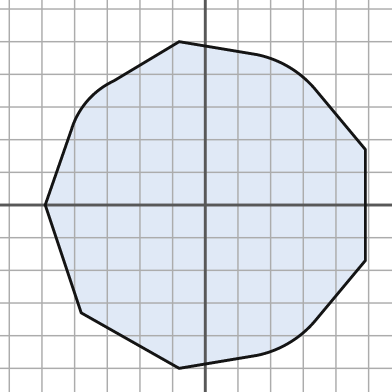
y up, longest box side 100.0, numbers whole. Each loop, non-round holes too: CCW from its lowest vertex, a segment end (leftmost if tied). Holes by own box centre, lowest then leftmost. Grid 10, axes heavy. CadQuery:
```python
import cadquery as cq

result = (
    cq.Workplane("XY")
    .moveTo(-8.0, -50.0)
    .lineTo(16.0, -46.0)
    .threePointArc((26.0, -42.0), (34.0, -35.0))
    .lineTo(49.0, -17.0)
    .lineTo(49.0, 17.0)
    .lineTo(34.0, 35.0)
    .threePointArc((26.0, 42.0), (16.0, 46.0))
    .lineTo(-8.0, 50.0)
    .lineTo(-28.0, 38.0)
    .threePointArc((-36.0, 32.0), (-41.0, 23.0))
    .lineTo(-49.0, 0.0)
    .lineTo(-38.0, -33.0)
    .close()
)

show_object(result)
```